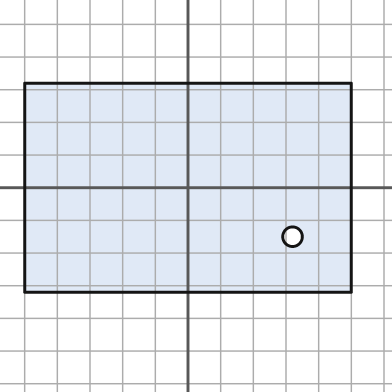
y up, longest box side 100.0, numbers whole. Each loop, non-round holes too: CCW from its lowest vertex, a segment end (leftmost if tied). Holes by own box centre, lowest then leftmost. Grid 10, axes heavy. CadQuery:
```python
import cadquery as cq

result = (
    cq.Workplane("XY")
    .moveTo(-50.0, -32.0)
    .lineTo(50.0, -32.0)
    .lineTo(50.0, 32.0)
    .lineTo(-50.0, 32.0)
    .close()
    .moveTo(32.0, -15.0)
    .circle(3.0)
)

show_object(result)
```